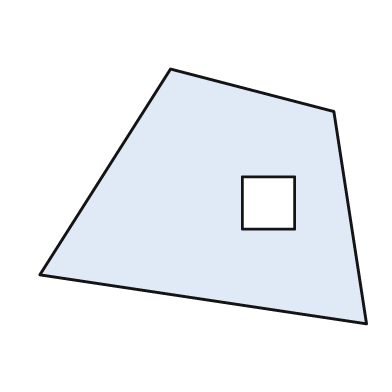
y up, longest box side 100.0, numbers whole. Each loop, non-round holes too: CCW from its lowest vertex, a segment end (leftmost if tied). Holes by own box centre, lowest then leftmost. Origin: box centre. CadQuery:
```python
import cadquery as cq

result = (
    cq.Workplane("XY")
    .moveTo(50.0, -39.0)
    .lineTo(40.0, 26.0)
    .lineTo(-10.0, 39.0)
    .lineTo(-50.0, -24.0)
    .close()
    .moveTo(12.0, -10.0)
    .lineTo(28.0, -10.0)
    .lineTo(28.0, 6.0)
    .lineTo(12.0, 6.0)
    .close()
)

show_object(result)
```